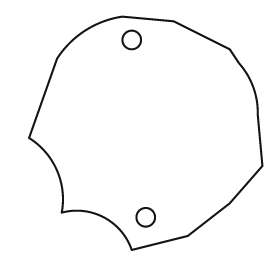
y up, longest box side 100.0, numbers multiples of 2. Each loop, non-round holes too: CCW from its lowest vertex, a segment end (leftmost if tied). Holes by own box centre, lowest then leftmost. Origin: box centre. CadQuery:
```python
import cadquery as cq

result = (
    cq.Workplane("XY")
    .moveTo(-6.0, -50.0)
    .lineTo(18.0, -44.0)
    .lineTo(36.0, -30.0)
    .lineTo(50.0, -14.0)
    .lineTo(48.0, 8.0)
    .threePointArc((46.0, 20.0), (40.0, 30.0))
    .lineTo(36.0, 36.0)
    .lineTo(12.0, 48.0)
    .lineTo(-10.0, 50.0)
    .threePointArc((-26.0, 44.0), (-38.0, 32.0))
    .lineTo(-50.0, -2.0)
    .threePointArc((-38.0, -16.0), (-36.0, -34.0))
    .threePointArc((-18.0, -36.0), (-6.0, -50.0))
    .close()
    .moveTo(0.0, -36.0)
    .circle(4.0)
    .moveTo(-6.0, 40.0)
    .circle(4.0)
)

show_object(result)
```